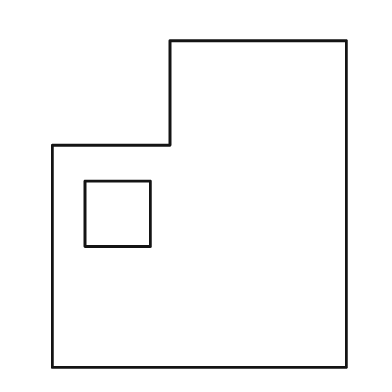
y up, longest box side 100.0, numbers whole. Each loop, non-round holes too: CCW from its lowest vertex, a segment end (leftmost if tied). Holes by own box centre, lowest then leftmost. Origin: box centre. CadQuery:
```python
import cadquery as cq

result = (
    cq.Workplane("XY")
    .moveTo(-45.0, -50.0)
    .lineTo(45.0, -50.0)
    .lineTo(45.0, 50.0)
    .lineTo(-9.0, 50.0)
    .lineTo(-9.0, 18.0)
    .lineTo(-45.0, 18.0)
    .close()
    .moveTo(-35.0, -13.0)
    .lineTo(-15.0, -13.0)
    .lineTo(-15.0, 7.0)
    .lineTo(-35.0, 7.0)
    .close()
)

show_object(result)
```